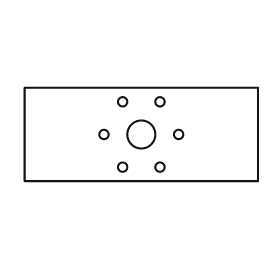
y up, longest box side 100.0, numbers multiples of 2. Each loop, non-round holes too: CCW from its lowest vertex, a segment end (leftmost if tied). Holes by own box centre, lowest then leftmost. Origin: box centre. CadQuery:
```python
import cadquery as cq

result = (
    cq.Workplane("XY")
    .moveTo(-50.0, -20.0)
    .lineTo(50.0, -20.0)
    .lineTo(50.0, 20.0)
    .lineTo(-50.0, 20.0)
    .close()
    .moveTo(-8.0, -14.0)
    .circle(2.0)
    .moveTo(8.0, -14.0)
    .circle(2.0)
    .moveTo(-16.0, 0.0)
    .circle(2.0)
    .moveTo(0.0, 0.0)
    .circle(6.0)
    .moveTo(16.0, 0.0)
    .circle(2.0)
    .moveTo(-8.0, 14.0)
    .circle(2.0)
    .moveTo(8.0, 14.0)
    .circle(2.0)
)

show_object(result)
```